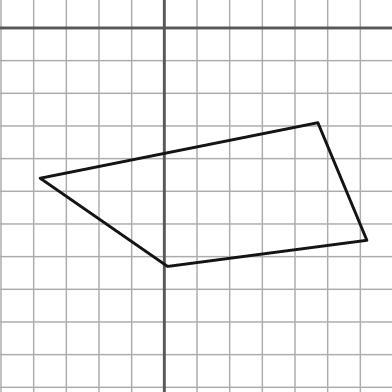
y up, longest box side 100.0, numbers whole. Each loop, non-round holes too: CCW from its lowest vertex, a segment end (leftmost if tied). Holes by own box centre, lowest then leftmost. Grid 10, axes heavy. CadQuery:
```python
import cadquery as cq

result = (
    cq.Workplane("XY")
    .moveTo(1.0, -73.0)
    .lineTo(62.0, -65.0)
    .lineTo(47.0, -29.0)
    .lineTo(-38.0, -46.0)
    .close()
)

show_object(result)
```